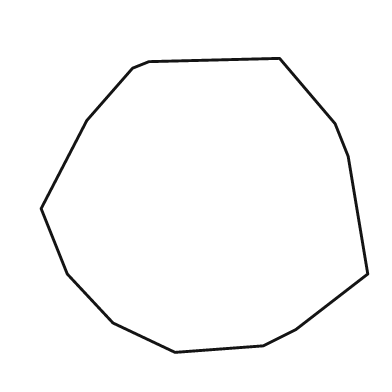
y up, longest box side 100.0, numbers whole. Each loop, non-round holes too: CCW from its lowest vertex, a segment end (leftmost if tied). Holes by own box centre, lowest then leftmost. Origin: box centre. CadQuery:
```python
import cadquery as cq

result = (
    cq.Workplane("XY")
    .moveTo(-9.0, -45.0)
    .lineTo(18.0, -43.0)
    .lineTo(28.0, -38.0)
    .lineTo(50.0, -21.0)
    .lineTo(44.0, 15.0)
    .lineTo(40.0, 25.0)
    .lineTo(23.0, 45.0)
    .lineTo(-17.0, 44.0)
    .lineTo(-22.0, 42.0)
    .lineTo(-36.0, 26.0)
    .lineTo(-50.0, -1.0)
    .lineTo(-42.0, -21.0)
    .lineTo(-28.0, -36.0)
    .close()
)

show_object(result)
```